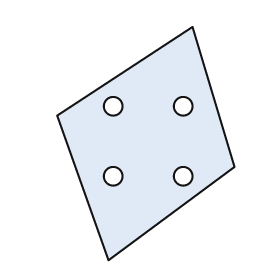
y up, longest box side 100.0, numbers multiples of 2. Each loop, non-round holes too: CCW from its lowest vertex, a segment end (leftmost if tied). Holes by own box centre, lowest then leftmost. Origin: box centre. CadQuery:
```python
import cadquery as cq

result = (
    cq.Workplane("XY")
    .moveTo(-16.0, -50.0)
    .lineTo(38.0, -10.0)
    .lineTo(20.0, 50.0)
    .lineTo(-38.0, 12.0)
    .close()
    .moveTo(-14.0, -14.0)
    .circle(4.0)
    .moveTo(16.0, -14.0)
    .circle(4.0)
    .moveTo(-14.0, 16.0)
    .circle(4.0)
    .moveTo(16.0, 16.0)
    .circle(4.0)
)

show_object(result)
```